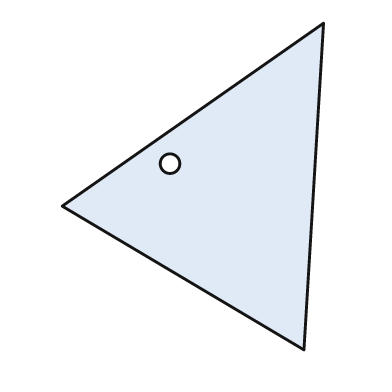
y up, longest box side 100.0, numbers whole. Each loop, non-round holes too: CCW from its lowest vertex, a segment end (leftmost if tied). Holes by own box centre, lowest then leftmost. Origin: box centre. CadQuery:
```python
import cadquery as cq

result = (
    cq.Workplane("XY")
    .moveTo(34.0, -50.0)
    .lineTo(40.0, 50.0)
    .lineTo(-40.0, -6.0)
    .close()
    .moveTo(-7.0, 7.0)
    .circle(3.0)
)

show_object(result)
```